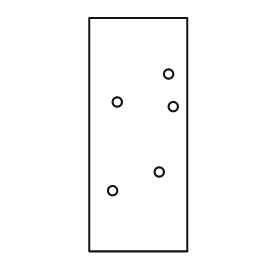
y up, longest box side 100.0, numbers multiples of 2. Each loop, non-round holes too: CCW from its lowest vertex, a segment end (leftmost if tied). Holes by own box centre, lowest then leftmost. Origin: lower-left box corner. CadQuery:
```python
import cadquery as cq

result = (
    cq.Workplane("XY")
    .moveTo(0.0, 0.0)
    .lineTo(42.0, 0.0)
    .lineTo(42.0, 100.0)
    .lineTo(0.0, 100.0)
    .close()
    .moveTo(10.0, 26.0)
    .circle(2.0)
    .moveTo(30.0, 34.0)
    .circle(2.0)
    .moveTo(36.0, 62.0)
    .circle(2.0)
    .moveTo(12.0, 64.0)
    .circle(2.0)
    .moveTo(34.0, 76.0)
    .circle(2.0)
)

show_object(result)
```